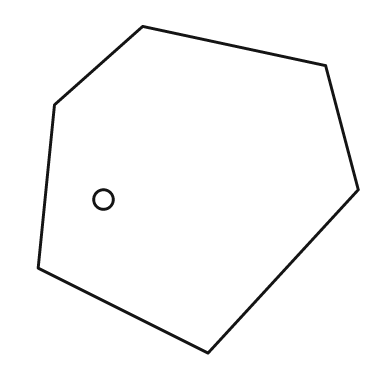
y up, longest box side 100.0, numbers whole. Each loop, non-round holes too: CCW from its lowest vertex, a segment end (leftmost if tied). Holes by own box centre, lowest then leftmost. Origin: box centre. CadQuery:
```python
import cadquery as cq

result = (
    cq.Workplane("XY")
    .moveTo(3.0, -50.0)
    .lineTo(49.0, 0.0)
    .lineTo(39.0, 38.0)
    .lineTo(-17.0, 50.0)
    .lineTo(-44.0, 26.0)
    .lineTo(-49.0, -24.0)
    .close()
    .moveTo(-29.0, -3.0)
    .circle(3.0)
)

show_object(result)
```